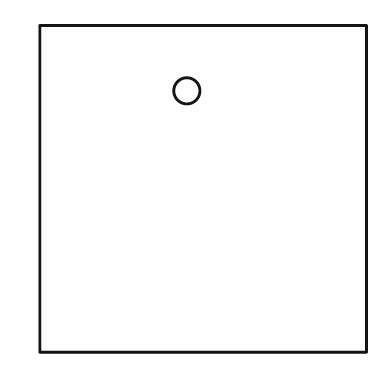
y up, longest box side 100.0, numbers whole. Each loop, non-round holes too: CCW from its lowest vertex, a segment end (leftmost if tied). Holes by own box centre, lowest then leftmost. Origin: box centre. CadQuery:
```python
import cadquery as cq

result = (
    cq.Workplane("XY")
    .moveTo(-50.0, -50.0)
    .lineTo(50.0, -50.0)
    .lineTo(50.0, 50.0)
    .lineTo(-50.0, 50.0)
    .close()
    .moveTo(-5.0, 30.0)
    .circle(4.0)
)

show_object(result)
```